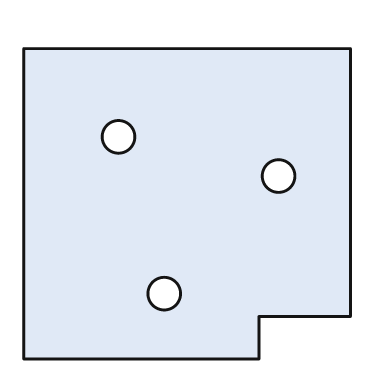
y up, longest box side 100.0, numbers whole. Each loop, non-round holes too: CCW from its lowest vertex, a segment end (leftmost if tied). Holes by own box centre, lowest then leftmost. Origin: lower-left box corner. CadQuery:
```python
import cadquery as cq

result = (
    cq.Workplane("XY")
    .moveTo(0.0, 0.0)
    .lineTo(72.0, 0.0)
    .lineTo(72.0, 13.0)
    .lineTo(100.0, 13.0)
    .lineTo(100.0, 95.0)
    .lineTo(0.0, 95.0)
    .close()
    .moveTo(43.0, 20.0)
    .circle(5.0)
    .moveTo(78.0, 56.0)
    .circle(5.0)
    .moveTo(29.0, 68.0)
    .circle(5.0)
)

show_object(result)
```